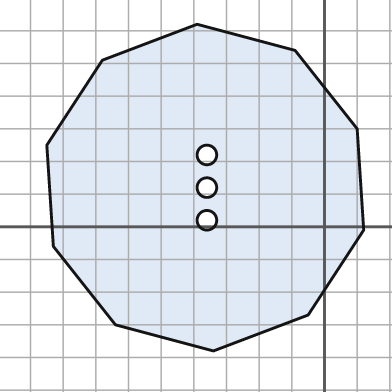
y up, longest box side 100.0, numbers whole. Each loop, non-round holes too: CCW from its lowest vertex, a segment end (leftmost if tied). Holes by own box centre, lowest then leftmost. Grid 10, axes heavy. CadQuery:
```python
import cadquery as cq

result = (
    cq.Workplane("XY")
    .moveTo(-34.0, -38.0)
    .lineTo(-5.0, -27.0)
    .lineTo(12.0, -1.0)
    .lineTo(10.0, 30.0)
    .lineTo(-9.0, 54.0)
    .lineTo(-39.0, 62.0)
    .lineTo(-68.0, 51.0)
    .lineTo(-85.0, 25.0)
    .lineTo(-83.0, -6.0)
    .lineTo(-64.0, -30.0)
    .close()
    .moveTo(-36.0, 2.0)
    .circle(3.0)
    .moveTo(-36.0, 12.0)
    .circle(3.0)
    .moveTo(-36.0, 22.0)
    .circle(3.0)
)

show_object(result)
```